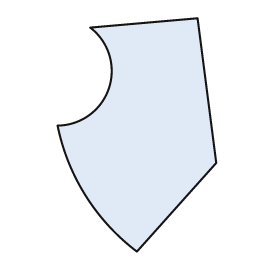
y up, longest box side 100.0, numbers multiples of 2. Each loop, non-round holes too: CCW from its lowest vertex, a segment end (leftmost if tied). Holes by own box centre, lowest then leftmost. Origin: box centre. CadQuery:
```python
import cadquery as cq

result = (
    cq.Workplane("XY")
    .moveTo(0.0, -50.0)
    .lineTo(34.0, -12.0)
    .lineTo(26.0, 50.0)
    .lineTo(-20.0, 46.0)
    .threePointArc((-12.0, 20.0), (-34.0, 4.0))
    .threePointArc((-22.0, -26.0), (0.0, -50.0))
    .close()
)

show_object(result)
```